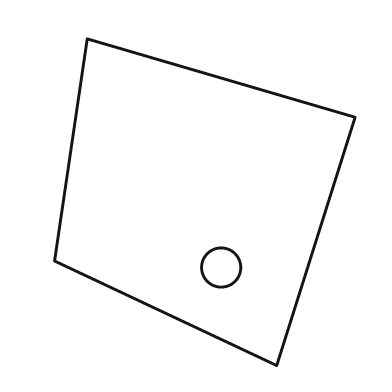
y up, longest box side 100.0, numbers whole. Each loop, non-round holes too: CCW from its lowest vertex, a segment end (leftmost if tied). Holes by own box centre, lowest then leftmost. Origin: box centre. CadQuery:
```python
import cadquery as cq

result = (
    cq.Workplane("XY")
    .moveTo(22.0, -50.0)
    .lineTo(46.0, 26.0)
    .lineTo(-36.0, 50.0)
    .lineTo(-46.0, -18.0)
    .close()
    .moveTo(5.0, -20.0)
    .circle(6.0)
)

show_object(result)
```